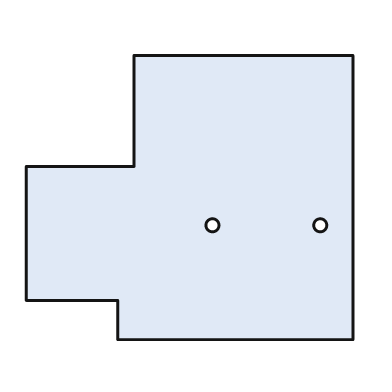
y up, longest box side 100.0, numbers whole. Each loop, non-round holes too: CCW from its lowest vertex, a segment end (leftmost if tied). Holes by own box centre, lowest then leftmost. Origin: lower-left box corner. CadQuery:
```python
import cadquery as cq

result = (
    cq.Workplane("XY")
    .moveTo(28.0, 0.0)
    .lineTo(100.0, 0.0)
    .lineTo(100.0, 87.0)
    .lineTo(33.0, 87.0)
    .lineTo(33.0, 53.0)
    .lineTo(0.0, 53.0)
    .lineTo(0.0, 12.0)
    .lineTo(28.0, 12.0)
    .close()
    .moveTo(57.0, 35.0)
    .circle(2.0)
    .moveTo(90.0, 35.0)
    .circle(2.0)
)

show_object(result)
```